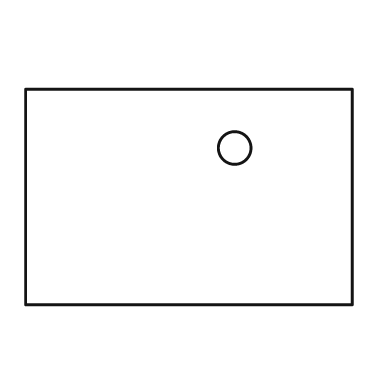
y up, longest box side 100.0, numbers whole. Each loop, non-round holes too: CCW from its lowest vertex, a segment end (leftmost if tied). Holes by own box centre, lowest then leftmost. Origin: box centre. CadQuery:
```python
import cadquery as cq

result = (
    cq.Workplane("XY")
    .moveTo(-50.0, -33.0)
    .lineTo(50.0, -33.0)
    .lineTo(50.0, 33.0)
    .lineTo(-50.0, 33.0)
    .close()
    .moveTo(14.0, 15.0)
    .circle(5.0)
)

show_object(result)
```